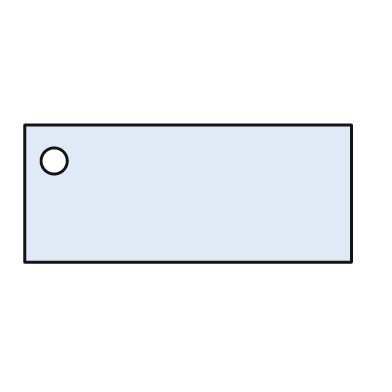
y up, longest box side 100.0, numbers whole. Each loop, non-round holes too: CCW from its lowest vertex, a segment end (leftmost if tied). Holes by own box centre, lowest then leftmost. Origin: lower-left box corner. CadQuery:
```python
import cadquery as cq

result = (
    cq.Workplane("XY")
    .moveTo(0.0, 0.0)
    .lineTo(100.0, 0.0)
    .lineTo(100.0, 42.0)
    .lineTo(0.0, 42.0)
    .close()
    .moveTo(9.0, 31.0)
    .circle(4.0)
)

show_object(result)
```